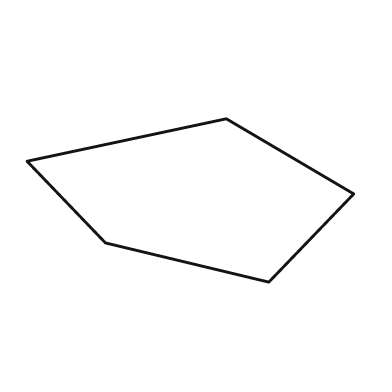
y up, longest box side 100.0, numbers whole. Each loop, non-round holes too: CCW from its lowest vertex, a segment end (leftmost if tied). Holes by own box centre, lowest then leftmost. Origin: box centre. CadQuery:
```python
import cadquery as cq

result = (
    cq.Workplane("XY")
    .moveTo(24.0, -25.0)
    .lineTo(50.0, 2.0)
    .lineTo(11.0, 25.0)
    .lineTo(-50.0, 12.0)
    .lineTo(-26.0, -13.0)
    .close()
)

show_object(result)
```